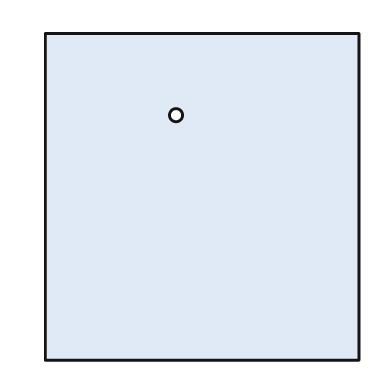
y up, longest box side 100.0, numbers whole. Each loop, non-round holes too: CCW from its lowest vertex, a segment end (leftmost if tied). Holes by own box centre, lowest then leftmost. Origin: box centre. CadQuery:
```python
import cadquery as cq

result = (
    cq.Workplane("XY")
    .moveTo(-48.0, -50.0)
    .lineTo(48.0, -50.0)
    .lineTo(48.0, 50.0)
    .lineTo(-48.0, 50.0)
    .close()
    .moveTo(-8.0, 25.0)
    .circle(2.0)
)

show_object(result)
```